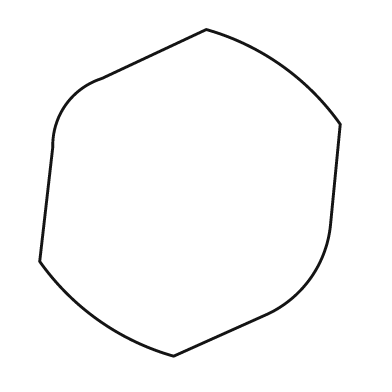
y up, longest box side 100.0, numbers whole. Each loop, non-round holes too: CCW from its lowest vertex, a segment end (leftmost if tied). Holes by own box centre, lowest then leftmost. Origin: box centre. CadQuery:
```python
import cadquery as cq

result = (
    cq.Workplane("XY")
    .moveTo(-5.0, -50.0)
    .lineTo(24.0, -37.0)
    .threePointArc((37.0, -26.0), (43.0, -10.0))
    .lineTo(46.0, 21.0)
    .threePointArc((28.0, 39.0), (5.0, 50.0))
    .lineTo(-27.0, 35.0)
    .threePointArc((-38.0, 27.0), (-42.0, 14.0))
    .lineTo(-46.0, -21.0)
    .threePointArc((-28.0, -39.0), (-5.0, -50.0))
    .close()
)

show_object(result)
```